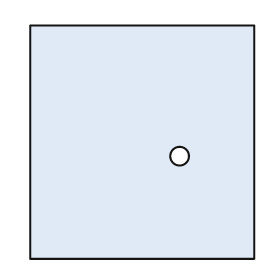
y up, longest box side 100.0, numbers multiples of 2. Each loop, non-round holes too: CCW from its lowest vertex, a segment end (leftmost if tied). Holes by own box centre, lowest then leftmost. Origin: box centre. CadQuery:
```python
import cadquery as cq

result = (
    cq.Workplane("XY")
    .moveTo(-48.0, -50.0)
    .lineTo(48.0, -50.0)
    .lineTo(48.0, 50.0)
    .lineTo(-48.0, 50.0)
    .close()
    .moveTo(16.0, -6.0)
    .circle(4.0)
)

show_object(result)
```